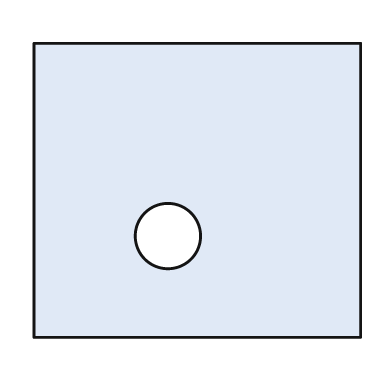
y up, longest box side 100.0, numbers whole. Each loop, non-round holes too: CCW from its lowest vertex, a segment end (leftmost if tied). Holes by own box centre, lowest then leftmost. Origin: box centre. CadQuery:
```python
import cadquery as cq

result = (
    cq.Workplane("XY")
    .moveTo(-50.0, -45.0)
    .lineTo(50.0, -45.0)
    .lineTo(50.0, 45.0)
    .lineTo(-50.0, 45.0)
    .close()
    .moveTo(-9.0, -14.0)
    .circle(10.0)
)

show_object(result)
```